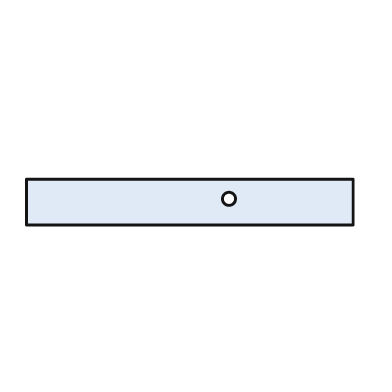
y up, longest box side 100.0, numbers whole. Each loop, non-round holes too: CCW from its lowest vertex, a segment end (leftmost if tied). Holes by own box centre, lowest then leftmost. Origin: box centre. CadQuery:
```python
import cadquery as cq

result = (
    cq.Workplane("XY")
    .moveTo(-50.0, -7.0)
    .lineTo(50.0, -7.0)
    .lineTo(50.0, 7.0)
    .lineTo(-50.0, 7.0)
    .close()
    .moveTo(12.0, 1.0)
    .circle(2.0)
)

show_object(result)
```